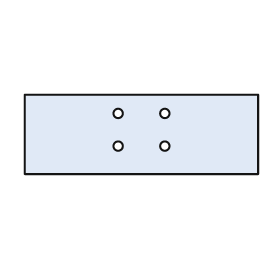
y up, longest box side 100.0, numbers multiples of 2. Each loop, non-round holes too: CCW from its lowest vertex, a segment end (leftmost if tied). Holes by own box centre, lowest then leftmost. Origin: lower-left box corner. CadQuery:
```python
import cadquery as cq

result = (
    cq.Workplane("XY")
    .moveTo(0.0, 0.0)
    .lineTo(100.0, 0.0)
    .lineTo(100.0, 34.0)
    .lineTo(0.0, 34.0)
    .close()
    .moveTo(40.0, 12.0)
    .circle(2.0)
    .moveTo(60.0, 12.0)
    .circle(2.0)
    .moveTo(40.0, 26.0)
    .circle(2.0)
    .moveTo(60.0, 26.0)
    .circle(2.0)
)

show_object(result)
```